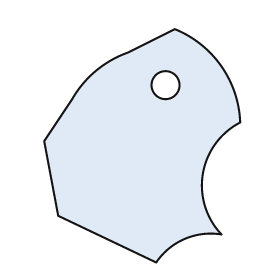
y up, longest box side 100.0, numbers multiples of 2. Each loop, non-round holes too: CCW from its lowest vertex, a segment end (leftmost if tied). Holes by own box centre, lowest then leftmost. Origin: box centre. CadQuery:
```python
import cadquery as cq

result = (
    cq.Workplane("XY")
    .moveTo(6.0, -50.0)
    .threePointArc((18.0, -40.0), (34.0, -38.0))
    .threePointArc((26.0, -12.0), (42.0, 10.0))
    .threePointArc((34.0, 34.0), (14.0, 50.0))
    .lineTo(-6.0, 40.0)
    .threePointArc((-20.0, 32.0), (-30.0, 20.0))
    .lineTo(-42.0, 2.0)
    .lineTo(-36.0, -30.0)
    .close()
    .moveTo(10.0, 26.0)
    .circle(6.0)
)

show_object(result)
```